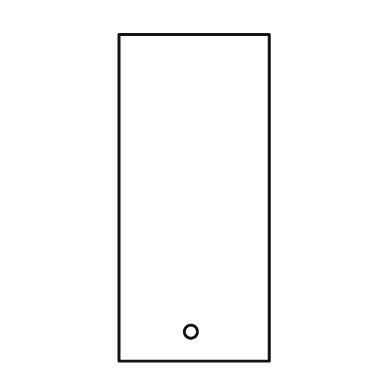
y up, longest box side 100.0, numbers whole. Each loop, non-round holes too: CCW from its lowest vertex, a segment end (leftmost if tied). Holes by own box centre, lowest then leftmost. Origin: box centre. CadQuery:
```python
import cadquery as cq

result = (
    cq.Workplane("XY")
    .moveTo(-23.0, -50.0)
    .lineTo(23.0, -50.0)
    .lineTo(23.0, 50.0)
    .lineTo(-23.0, 50.0)
    .close()
    .moveTo(-1.0, -41.0)
    .circle(2.0)
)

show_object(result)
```